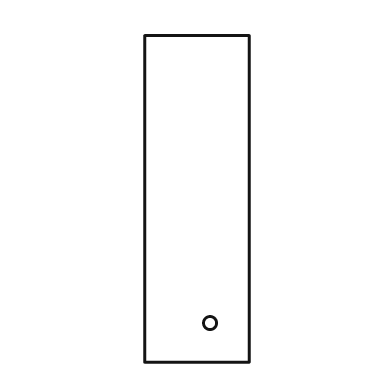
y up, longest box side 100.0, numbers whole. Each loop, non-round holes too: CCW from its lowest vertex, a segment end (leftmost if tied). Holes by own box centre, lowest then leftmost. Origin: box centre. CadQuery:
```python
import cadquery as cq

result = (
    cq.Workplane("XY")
    .moveTo(-16.0, -50.0)
    .lineTo(16.0, -50.0)
    .lineTo(16.0, 50.0)
    .lineTo(-16.0, 50.0)
    .close()
    .moveTo(4.0, -38.0)
    .circle(2.0)
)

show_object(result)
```